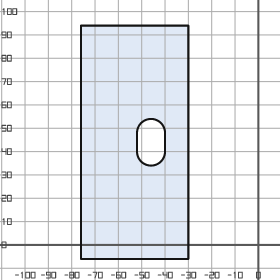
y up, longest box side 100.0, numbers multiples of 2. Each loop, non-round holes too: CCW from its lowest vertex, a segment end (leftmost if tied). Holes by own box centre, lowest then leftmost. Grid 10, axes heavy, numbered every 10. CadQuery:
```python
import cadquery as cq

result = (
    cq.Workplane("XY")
    .moveTo(-76.0, -6.0)
    .lineTo(-30.0, -6.0)
    .lineTo(-30.0, 94.0)
    .lineTo(-76.0, 94.0)
    .close()
    .moveTo(-52.0, 40.0)
    .threePointArc((-46.0, 34.0), (-40.0, 40.0))
    .lineTo(-40.0, 48.0)
    .threePointArc((-46.0, 54.0), (-52.0, 48.0))
    .close()
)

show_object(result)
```